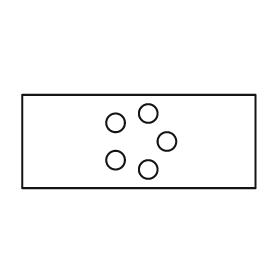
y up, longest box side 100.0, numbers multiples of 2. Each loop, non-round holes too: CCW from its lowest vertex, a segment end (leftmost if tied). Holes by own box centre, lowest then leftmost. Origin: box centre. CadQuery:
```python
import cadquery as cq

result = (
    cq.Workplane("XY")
    .moveTo(-50.0, -20.0)
    .lineTo(50.0, -20.0)
    .lineTo(50.0, 20.0)
    .lineTo(-50.0, 20.0)
    .close()
    .moveTo(4.0, -12.0)
    .circle(4.0)
    .moveTo(-10.0, -8.0)
    .circle(4.0)
    .moveTo(12.0, 0.0)
    .circle(4.0)
    .moveTo(-10.0, 8.0)
    .circle(4.0)
    .moveTo(4.0, 12.0)
    .circle(4.0)
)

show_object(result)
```